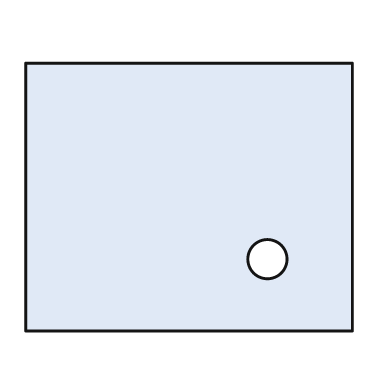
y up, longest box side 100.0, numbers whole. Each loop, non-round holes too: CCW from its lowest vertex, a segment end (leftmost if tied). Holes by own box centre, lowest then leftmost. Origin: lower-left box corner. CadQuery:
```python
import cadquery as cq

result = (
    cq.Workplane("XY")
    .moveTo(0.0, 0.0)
    .lineTo(100.0, 0.0)
    .lineTo(100.0, 82.0)
    .lineTo(0.0, 82.0)
    .close()
    .moveTo(74.0, 22.0)
    .circle(6.0)
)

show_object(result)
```